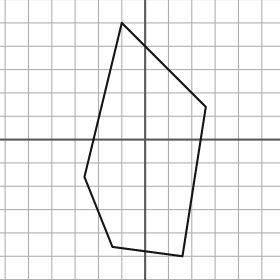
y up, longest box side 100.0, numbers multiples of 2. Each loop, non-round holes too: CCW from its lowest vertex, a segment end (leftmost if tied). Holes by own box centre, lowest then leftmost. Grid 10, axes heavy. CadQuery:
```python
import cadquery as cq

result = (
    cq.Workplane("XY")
    .moveTo(16.0, -50.0)
    .lineTo(26.0, 14.0)
    .lineTo(-10.0, 50.0)
    .lineTo(-26.0, -16.0)
    .lineTo(-14.0, -46.0)
    .close()
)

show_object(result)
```